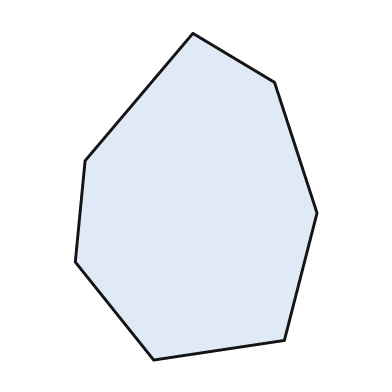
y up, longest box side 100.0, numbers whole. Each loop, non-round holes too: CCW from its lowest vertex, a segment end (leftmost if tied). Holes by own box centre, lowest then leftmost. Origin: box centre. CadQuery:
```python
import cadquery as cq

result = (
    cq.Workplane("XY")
    .moveTo(-13.0, -50.0)
    .lineTo(27.0, -44.0)
    .lineTo(37.0, -5.0)
    .lineTo(24.0, 35.0)
    .lineTo(-1.0, 50.0)
    .lineTo(-34.0, 11.0)
    .lineTo(-37.0, -20.0)
    .close()
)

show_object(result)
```